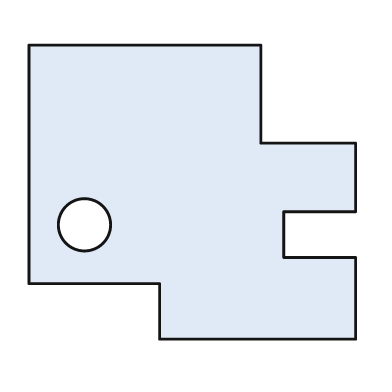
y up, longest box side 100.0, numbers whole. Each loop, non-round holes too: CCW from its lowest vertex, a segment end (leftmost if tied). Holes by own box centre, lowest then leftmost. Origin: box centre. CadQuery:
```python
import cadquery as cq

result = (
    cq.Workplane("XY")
    .moveTo(-10.0, -45.0)
    .lineTo(50.0, -45.0)
    .lineTo(50.0, -20.0)
    .lineTo(28.0, -20.0)
    .lineTo(28.0, -6.0)
    .lineTo(50.0, -6.0)
    .lineTo(50.0, 15.0)
    .lineTo(21.0, 15.0)
    .lineTo(21.0, 45.0)
    .lineTo(-50.0, 45.0)
    .lineTo(-50.0, -28.0)
    .lineTo(-10.0, -28.0)
    .close()
    .moveTo(-33.0, -10.0)
    .circle(8.0)
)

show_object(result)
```